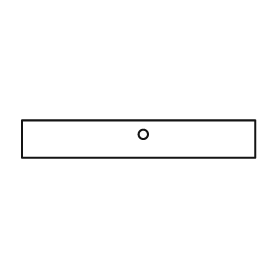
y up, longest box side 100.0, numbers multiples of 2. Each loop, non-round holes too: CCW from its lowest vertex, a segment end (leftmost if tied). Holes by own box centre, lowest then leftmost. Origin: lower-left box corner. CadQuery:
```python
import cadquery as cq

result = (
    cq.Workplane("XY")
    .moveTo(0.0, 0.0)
    .lineTo(100.0, 0.0)
    .lineTo(100.0, 16.0)
    .lineTo(0.0, 16.0)
    .close()
    .moveTo(52.0, 10.0)
    .circle(2.0)
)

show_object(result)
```